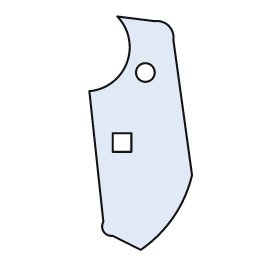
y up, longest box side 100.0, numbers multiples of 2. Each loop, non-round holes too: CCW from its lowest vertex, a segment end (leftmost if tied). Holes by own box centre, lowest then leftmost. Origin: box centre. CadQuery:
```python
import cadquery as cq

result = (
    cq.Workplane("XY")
    .moveTo(0.0, -50.0)
    .threePointArc((14.0, -36.0), (22.0, -18.0))
    .lineTo(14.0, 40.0)
    .threePointArc((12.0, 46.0), (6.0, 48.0))
    .lineTo(-10.0, 50.0)
    .threePointArc((-6.0, 30.0), (-22.0, 18.0))
    .lineTo(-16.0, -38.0)
    .threePointArc((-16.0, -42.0), (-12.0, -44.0))
    .close()
    .moveTo(-12.0, -8.0)
    .lineTo(-4.0, -8.0)
    .lineTo(-4.0, 0.0)
    .lineTo(-12.0, 0.0)
    .close()
    .moveTo(2.0, 26.0)
    .circle(4.0)
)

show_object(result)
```